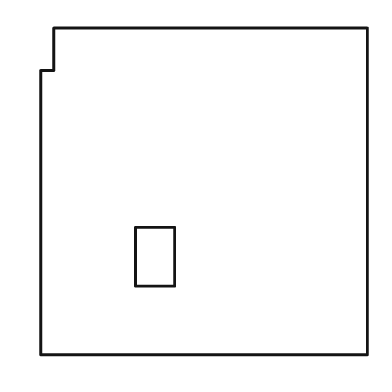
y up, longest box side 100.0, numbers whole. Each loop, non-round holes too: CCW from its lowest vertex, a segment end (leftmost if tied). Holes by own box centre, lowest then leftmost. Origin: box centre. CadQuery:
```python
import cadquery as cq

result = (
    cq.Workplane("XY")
    .moveTo(-50.0, -50.0)
    .lineTo(50.0, -50.0)
    .lineTo(50.0, 50.0)
    .lineTo(-46.0, 50.0)
    .lineTo(-46.0, 37.0)
    .lineTo(-50.0, 37.0)
    .close()
    .moveTo(-21.0, -29.0)
    .lineTo(-9.0, -29.0)
    .lineTo(-9.0, -11.0)
    .lineTo(-21.0, -11.0)
    .close()
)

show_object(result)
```